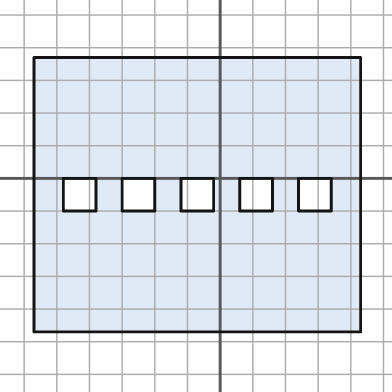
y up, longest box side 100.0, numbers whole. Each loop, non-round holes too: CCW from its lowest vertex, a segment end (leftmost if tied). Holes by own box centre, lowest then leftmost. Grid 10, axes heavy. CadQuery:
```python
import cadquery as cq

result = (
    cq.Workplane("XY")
    .moveTo(-57.0, -47.0)
    .lineTo(43.0, -47.0)
    .lineTo(43.0, 37.0)
    .lineTo(-57.0, 37.0)
    .close()
    .moveTo(-48.0, -10.0)
    .lineTo(-38.0, -10.0)
    .lineTo(-38.0, 0.0)
    .lineTo(-48.0, 0.0)
    .close()
    .moveTo(-30.0, -10.0)
    .lineTo(-20.0, -10.0)
    .lineTo(-20.0, 0.0)
    .lineTo(-30.0, 0.0)
    .close()
    .moveTo(-12.0, -10.0)
    .lineTo(-2.0, -10.0)
    .lineTo(-2.0, 0.0)
    .lineTo(-12.0, 0.0)
    .close()
    .moveTo(6.0, -10.0)
    .lineTo(16.0, -10.0)
    .lineTo(16.0, 0.0)
    .lineTo(6.0, 0.0)
    .close()
    .moveTo(24.0, -10.0)
    .lineTo(34.0, -10.0)
    .lineTo(34.0, 0.0)
    .lineTo(24.0, 0.0)
    .close()
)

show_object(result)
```